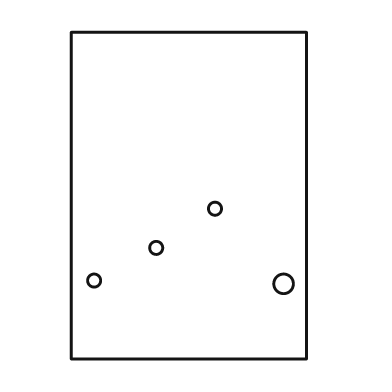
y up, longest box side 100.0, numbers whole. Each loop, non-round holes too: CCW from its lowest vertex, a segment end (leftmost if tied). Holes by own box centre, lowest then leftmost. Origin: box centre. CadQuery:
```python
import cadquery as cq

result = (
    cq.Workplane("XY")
    .moveTo(-36.0, -50.0)
    .lineTo(36.0, -50.0)
    .lineTo(36.0, 50.0)
    .lineTo(-36.0, 50.0)
    .close()
    .moveTo(29.0, -27.0)
    .circle(3.0)
    .moveTo(-29.0, -26.0)
    .circle(2.0)
    .moveTo(-10.0, -16.0)
    .circle(2.0)
    .moveTo(8.0, -4.0)
    .circle(2.0)
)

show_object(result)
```